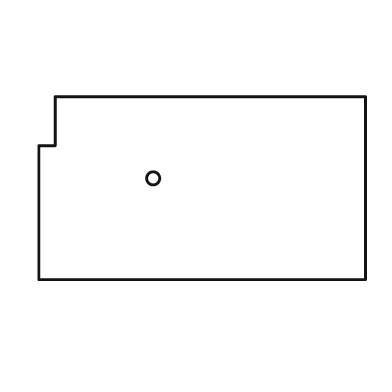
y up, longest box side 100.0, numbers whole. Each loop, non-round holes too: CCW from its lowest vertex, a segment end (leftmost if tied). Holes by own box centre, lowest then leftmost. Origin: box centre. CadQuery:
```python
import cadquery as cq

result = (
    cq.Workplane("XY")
    .moveTo(-50.0, -28.0)
    .lineTo(50.0, -28.0)
    .lineTo(50.0, 28.0)
    .lineTo(-45.0, 28.0)
    .lineTo(-45.0, 13.0)
    .lineTo(-50.0, 13.0)
    .close()
    .moveTo(-15.0, 3.0)
    .circle(2.0)
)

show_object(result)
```